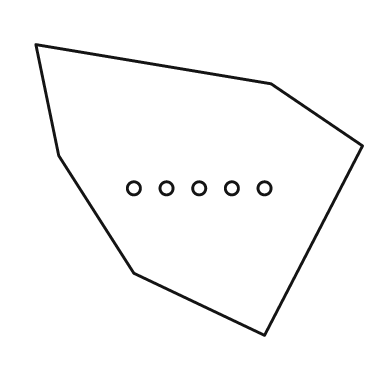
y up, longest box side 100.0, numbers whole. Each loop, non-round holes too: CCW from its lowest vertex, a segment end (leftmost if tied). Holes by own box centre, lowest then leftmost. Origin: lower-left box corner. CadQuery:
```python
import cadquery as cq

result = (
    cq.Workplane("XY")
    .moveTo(70.0, 0.0)
    .lineTo(100.0, 58.0)
    .lineTo(72.0, 77.0)
    .lineTo(0.0, 89.0)
    .lineTo(7.0, 55.0)
    .lineTo(30.0, 19.0)
    .close()
    .moveTo(30.0, 45.0)
    .circle(2.0)
    .moveTo(40.0, 45.0)
    .circle(2.0)
    .moveTo(50.0, 45.0)
    .circle(2.0)
    .moveTo(60.0, 45.0)
    .circle(2.0)
    .moveTo(70.0, 45.0)
    .circle(2.0)
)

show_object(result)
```